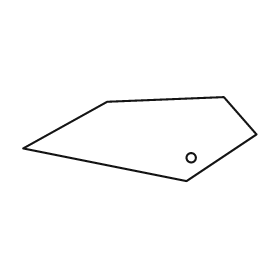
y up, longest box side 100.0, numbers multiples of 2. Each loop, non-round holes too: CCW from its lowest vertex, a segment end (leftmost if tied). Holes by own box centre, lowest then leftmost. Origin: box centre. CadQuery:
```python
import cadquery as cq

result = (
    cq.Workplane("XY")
    .moveTo(20.0, -18.0)
    .lineTo(50.0, 2.0)
    .lineTo(36.0, 18.0)
    .lineTo(-14.0, 16.0)
    .lineTo(-50.0, -4.0)
    .close()
    .moveTo(22.0, -8.0)
    .circle(2.0)
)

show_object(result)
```